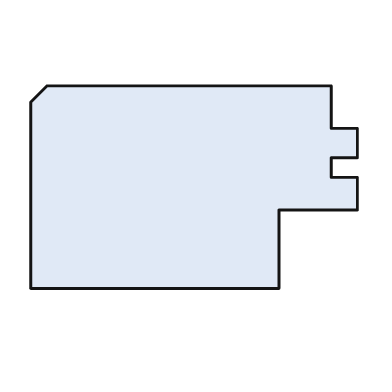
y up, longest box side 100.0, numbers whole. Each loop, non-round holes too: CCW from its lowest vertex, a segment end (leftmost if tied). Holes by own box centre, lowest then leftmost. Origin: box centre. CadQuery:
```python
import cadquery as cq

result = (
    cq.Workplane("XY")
    .moveTo(-50.0, -31.0)
    .lineTo(26.0, -31.0)
    .lineTo(26.0, -7.0)
    .lineTo(50.0, -7.0)
    .lineTo(50.0, 3.0)
    .lineTo(42.0, 3.0)
    .lineTo(42.0, 9.0)
    .lineTo(50.0, 9.0)
    .lineTo(50.0, 18.0)
    .lineTo(42.0, 18.0)
    .lineTo(42.0, 31.0)
    .lineTo(-45.0, 31.0)
    .lineTo(-50.0, 26.0)
    .close()
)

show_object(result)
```